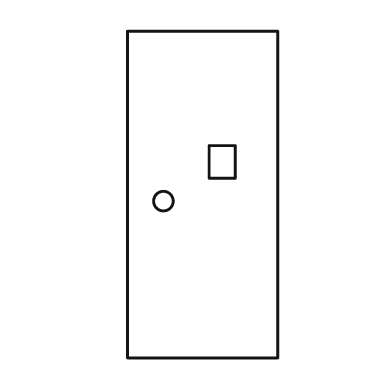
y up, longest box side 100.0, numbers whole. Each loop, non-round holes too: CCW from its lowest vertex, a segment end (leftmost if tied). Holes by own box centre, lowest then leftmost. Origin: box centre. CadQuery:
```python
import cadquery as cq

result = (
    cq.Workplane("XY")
    .moveTo(-23.0, -50.0)
    .lineTo(23.0, -50.0)
    .lineTo(23.0, 50.0)
    .lineTo(-23.0, 50.0)
    .close()
    .moveTo(-12.0, -2.0)
    .circle(3.0)
    .moveTo(2.0, 5.0)
    .lineTo(10.0, 5.0)
    .lineTo(10.0, 15.0)
    .lineTo(2.0, 15.0)
    .close()
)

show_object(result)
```